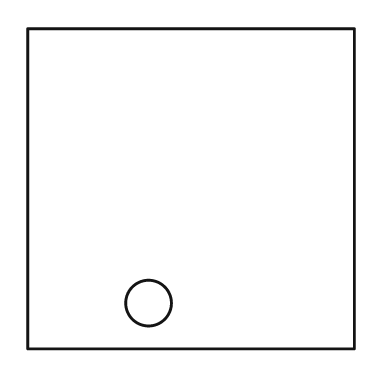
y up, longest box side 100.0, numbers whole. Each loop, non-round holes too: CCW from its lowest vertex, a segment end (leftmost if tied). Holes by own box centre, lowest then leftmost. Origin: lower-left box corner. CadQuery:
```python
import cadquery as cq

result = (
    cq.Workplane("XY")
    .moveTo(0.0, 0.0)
    .lineTo(100.0, 0.0)
    .lineTo(100.0, 98.0)
    .lineTo(0.0, 98.0)
    .close()
    .moveTo(37.0, 14.0)
    .circle(7.0)
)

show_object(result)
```